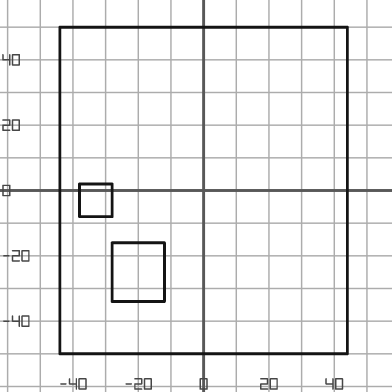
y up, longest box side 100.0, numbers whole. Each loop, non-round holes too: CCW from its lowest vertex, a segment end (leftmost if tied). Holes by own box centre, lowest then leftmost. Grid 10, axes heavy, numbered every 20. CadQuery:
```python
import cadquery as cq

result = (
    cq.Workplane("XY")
    .moveTo(-44.0, -50.0)
    .lineTo(44.0, -50.0)
    .lineTo(44.0, 50.0)
    .lineTo(-44.0, 50.0)
    .close()
    .moveTo(-28.0, -34.0)
    .lineTo(-12.0, -34.0)
    .lineTo(-12.0, -16.0)
    .lineTo(-28.0, -16.0)
    .close()
    .moveTo(-38.0, -8.0)
    .lineTo(-28.0, -8.0)
    .lineTo(-28.0, 2.0)
    .lineTo(-38.0, 2.0)
    .close()
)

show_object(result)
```